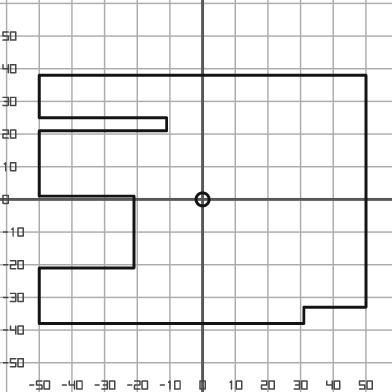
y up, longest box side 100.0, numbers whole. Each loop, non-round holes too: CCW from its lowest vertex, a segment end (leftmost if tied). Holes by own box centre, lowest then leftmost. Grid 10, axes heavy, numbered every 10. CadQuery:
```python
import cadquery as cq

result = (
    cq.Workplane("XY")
    .moveTo(-50.0, -38.0)
    .lineTo(31.0, -38.0)
    .lineTo(31.0, -33.0)
    .lineTo(50.0, -33.0)
    .lineTo(50.0, 38.0)
    .lineTo(-50.0, 38.0)
    .lineTo(-50.0, 25.0)
    .lineTo(-11.0, 25.0)
    .lineTo(-11.0, 21.0)
    .lineTo(-50.0, 21.0)
    .lineTo(-50.0, 1.0)
    .lineTo(-21.0, 1.0)
    .lineTo(-21.0, -21.0)
    .lineTo(-50.0, -21.0)
    .close()
    .moveTo(0.0, 0.0)
    .circle(2.0)
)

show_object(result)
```